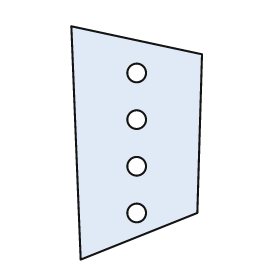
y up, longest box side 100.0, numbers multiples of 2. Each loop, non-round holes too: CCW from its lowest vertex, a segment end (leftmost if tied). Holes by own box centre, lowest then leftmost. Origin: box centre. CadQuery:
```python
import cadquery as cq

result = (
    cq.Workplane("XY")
    .moveTo(-24.0, -50.0)
    .lineTo(26.0, -30.0)
    .lineTo(28.0, 38.0)
    .lineTo(-28.0, 50.0)
    .close()
    .moveTo(0.0, -30.0)
    .circle(4.0)
    .moveTo(0.0, -10.0)
    .circle(4.0)
    .moveTo(0.0, 10.0)
    .circle(4.0)
    .moveTo(0.0, 30.0)
    .circle(4.0)
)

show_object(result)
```